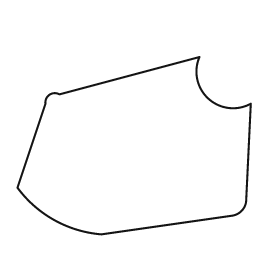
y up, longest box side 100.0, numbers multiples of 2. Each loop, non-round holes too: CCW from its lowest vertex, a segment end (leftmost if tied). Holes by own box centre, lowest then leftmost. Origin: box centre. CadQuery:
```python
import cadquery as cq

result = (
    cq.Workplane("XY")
    .moveTo(-14.0, -38.0)
    .lineTo(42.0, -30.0)
    .threePointArc((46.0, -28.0), (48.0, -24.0))
    .lineTo(50.0, 18.0)
    .threePointArc((32.0, 20.0), (28.0, 38.0))
    .lineTo(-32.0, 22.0)
    .threePointArc((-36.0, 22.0), (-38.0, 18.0))
    .lineTo(-50.0, -18.0)
    .threePointArc((-34.0, -32.0), (-14.0, -38.0))
    .close()
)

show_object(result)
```